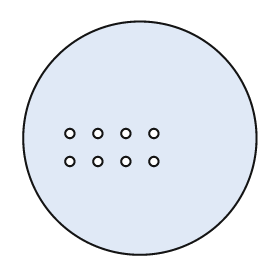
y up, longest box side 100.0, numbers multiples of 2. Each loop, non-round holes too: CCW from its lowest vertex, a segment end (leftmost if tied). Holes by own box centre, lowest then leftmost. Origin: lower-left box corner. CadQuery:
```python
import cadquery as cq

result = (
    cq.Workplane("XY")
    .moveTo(50.0, 50.0)
    .circle(50.0)
    .moveTo(20.0, 40.0)
    .circle(2.0)
    .moveTo(32.0, 40.0)
    .circle(2.0)
    .moveTo(44.0, 40.0)
    .circle(2.0)
    .moveTo(56.0, 40.0)
    .circle(2.0)
    .moveTo(20.0, 52.0)
    .circle(2.0)
    .moveTo(32.0, 52.0)
    .circle(2.0)
    .moveTo(44.0, 52.0)
    .circle(2.0)
    .moveTo(56.0, 52.0)
    .circle(2.0)
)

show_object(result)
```